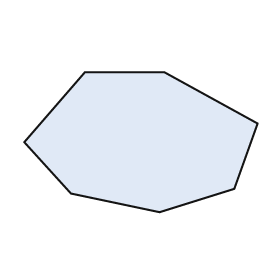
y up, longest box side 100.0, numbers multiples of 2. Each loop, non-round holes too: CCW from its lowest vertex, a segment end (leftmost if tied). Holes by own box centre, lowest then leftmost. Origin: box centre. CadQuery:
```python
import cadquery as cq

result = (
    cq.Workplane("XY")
    .moveTo(8.0, -30.0)
    .lineTo(40.0, -20.0)
    .lineTo(50.0, 8.0)
    .lineTo(10.0, 30.0)
    .lineTo(-24.0, 30.0)
    .lineTo(-50.0, 0.0)
    .lineTo(-30.0, -22.0)
    .close()
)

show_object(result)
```